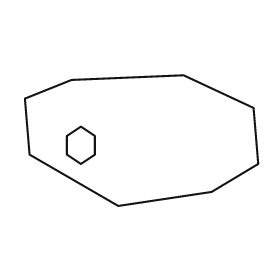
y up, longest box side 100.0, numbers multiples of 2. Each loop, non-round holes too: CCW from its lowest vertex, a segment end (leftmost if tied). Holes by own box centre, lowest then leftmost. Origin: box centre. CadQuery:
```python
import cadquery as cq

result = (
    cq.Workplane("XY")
    .moveTo(-10.0, -28.0)
    .lineTo(30.0, -22.0)
    .lineTo(50.0, -10.0)
    .lineTo(48.0, 14.0)
    .lineTo(18.0, 28.0)
    .lineTo(-30.0, 26.0)
    .lineTo(-50.0, 18.0)
    .lineTo(-48.0, -6.0)
    .close()
    .moveTo(-26.0, -10.0)
    .lineTo(-20.0, -6.0)
    .lineTo(-20.0, 2.0)
    .lineTo(-26.0, 6.0)
    .lineTo(-32.0, 2.0)
    .lineTo(-32.0, -6.0)
    .close()
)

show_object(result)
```